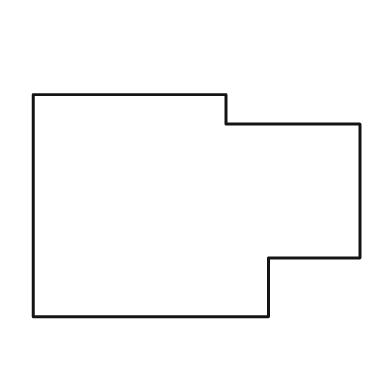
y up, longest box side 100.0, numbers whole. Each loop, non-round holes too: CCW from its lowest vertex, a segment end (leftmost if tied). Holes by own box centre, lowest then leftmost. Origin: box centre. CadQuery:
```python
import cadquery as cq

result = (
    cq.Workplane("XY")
    .moveTo(-50.0, -34.0)
    .lineTo(22.0, -34.0)
    .lineTo(22.0, -16.0)
    .lineTo(50.0, -16.0)
    .lineTo(50.0, 25.0)
    .lineTo(9.0, 25.0)
    .lineTo(9.0, 34.0)
    .lineTo(-50.0, 34.0)
    .close()
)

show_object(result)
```